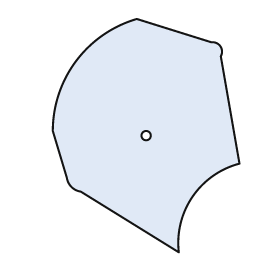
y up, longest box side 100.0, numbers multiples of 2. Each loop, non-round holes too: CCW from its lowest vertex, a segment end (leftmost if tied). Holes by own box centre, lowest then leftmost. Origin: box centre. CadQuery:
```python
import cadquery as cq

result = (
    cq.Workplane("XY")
    .moveTo(14.0, -50.0)
    .threePointArc((20.0, -26.0), (40.0, -12.0))
    .lineTo(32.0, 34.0)
    .threePointArc((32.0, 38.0), (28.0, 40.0))
    .lineTo(-4.0, 50.0)
    .threePointArc((-30.0, 32.0), (-40.0, 2.0))
    .lineTo(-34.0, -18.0)
    .threePointArc((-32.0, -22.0), (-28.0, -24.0))
    .close()
    .moveTo(0.0, 0.0)
    .circle(2.0)
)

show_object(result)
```